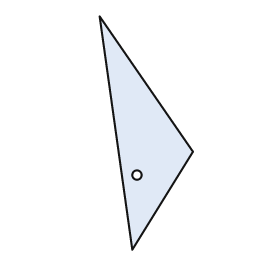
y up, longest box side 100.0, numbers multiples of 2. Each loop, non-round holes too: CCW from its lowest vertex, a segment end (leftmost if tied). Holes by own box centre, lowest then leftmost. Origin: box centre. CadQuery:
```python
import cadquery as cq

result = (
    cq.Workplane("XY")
    .moveTo(-6.0, -50.0)
    .lineTo(20.0, -8.0)
    .lineTo(-20.0, 50.0)
    .close()
    .moveTo(-4.0, -18.0)
    .circle(2.0)
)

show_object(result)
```